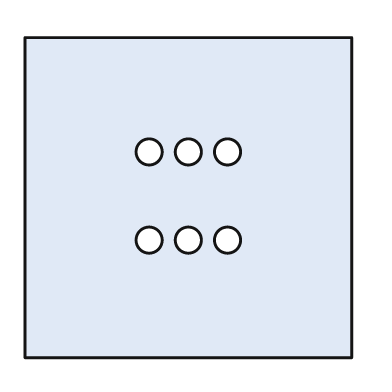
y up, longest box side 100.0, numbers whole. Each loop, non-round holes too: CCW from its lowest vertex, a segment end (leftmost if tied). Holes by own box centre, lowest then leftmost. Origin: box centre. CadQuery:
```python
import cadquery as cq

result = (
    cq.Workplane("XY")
    .moveTo(-50.0, -49.0)
    .lineTo(50.0, -49.0)
    .lineTo(50.0, 49.0)
    .lineTo(-50.0, 49.0)
    .close()
    .moveTo(-12.0, -13.0)
    .circle(4.0)
    .moveTo(0.0, -13.0)
    .circle(4.0)
    .moveTo(12.0, -13.0)
    .circle(4.0)
    .moveTo(-12.0, 14.0)
    .circle(4.0)
    .moveTo(0.0, 14.0)
    .circle(4.0)
    .moveTo(12.0, 14.0)
    .circle(4.0)
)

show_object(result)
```